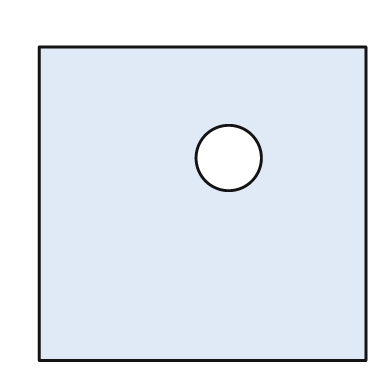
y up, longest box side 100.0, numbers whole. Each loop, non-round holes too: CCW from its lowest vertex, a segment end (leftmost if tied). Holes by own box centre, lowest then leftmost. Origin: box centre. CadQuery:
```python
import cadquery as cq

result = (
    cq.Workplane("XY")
    .moveTo(-50.0, -48.0)
    .lineTo(50.0, -48.0)
    .lineTo(50.0, 48.0)
    .lineTo(-50.0, 48.0)
    .close()
    .moveTo(8.0, 14.0)
    .circle(10.0)
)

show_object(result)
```